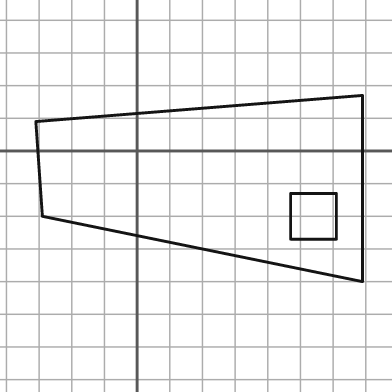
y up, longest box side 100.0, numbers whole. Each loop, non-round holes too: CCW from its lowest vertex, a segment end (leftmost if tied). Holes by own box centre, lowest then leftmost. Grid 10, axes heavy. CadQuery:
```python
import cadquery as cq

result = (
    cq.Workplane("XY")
    .moveTo(69.0, -40.0)
    .lineTo(69.0, 17.0)
    .lineTo(-31.0, 9.0)
    .lineTo(-29.0, -20.0)
    .close()
    .moveTo(47.0, -27.0)
    .lineTo(61.0, -27.0)
    .lineTo(61.0, -13.0)
    .lineTo(47.0, -13.0)
    .close()
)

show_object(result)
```